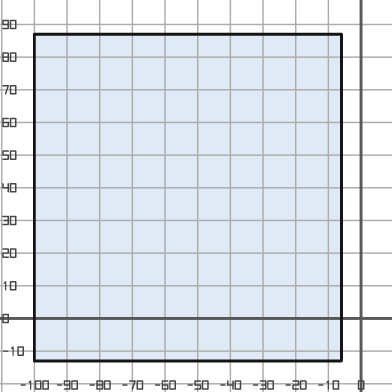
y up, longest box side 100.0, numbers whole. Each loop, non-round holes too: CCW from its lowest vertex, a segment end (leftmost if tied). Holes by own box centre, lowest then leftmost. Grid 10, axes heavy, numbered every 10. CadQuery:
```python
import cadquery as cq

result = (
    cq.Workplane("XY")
    .moveTo(-100.0, -13.0)
    .lineTo(-6.0, -13.0)
    .lineTo(-6.0, 87.0)
    .lineTo(-100.0, 87.0)
    .close()
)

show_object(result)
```